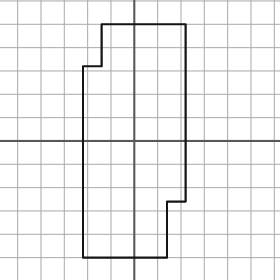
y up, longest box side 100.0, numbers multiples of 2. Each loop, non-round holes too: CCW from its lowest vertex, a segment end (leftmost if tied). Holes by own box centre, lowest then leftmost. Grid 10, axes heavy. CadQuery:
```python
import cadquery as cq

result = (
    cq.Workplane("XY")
    .moveTo(-22.0, -50.0)
    .lineTo(14.0, -50.0)
    .lineTo(14.0, -26.0)
    .lineTo(22.0, -26.0)
    .lineTo(22.0, 50.0)
    .lineTo(-14.0, 50.0)
    .lineTo(-14.0, 32.0)
    .lineTo(-22.0, 32.0)
    .close()
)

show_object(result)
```